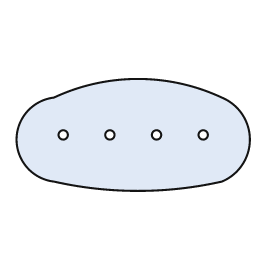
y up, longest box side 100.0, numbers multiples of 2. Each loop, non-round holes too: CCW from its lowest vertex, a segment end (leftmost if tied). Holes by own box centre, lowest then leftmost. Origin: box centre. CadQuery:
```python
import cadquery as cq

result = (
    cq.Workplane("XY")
    .moveTo(-34.0, -20.0)
    .threePointArc((2.0, -24.0), (38.0, -20.0))
    .threePointArc((50.0, -2.0), (38.0, 16.0))
    .threePointArc((2.0, 24.0), (-34.0, 16.0))
    .threePointArc((-50.0, -2.0), (-34.0, -20.0))
    .close()
    .moveTo(-30.0, 0.0)
    .circle(2.0)
    .moveTo(-10.0, 0.0)
    .circle(2.0)
    .moveTo(10.0, 0.0)
    .circle(2.0)
    .moveTo(30.0, 0.0)
    .circle(2.0)
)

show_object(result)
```